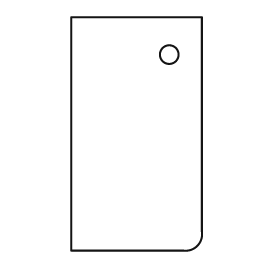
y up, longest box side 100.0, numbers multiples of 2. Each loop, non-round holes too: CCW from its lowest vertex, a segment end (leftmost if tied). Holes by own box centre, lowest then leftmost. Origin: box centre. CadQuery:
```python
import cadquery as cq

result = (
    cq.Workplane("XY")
    .moveTo(-28.0, -50.0)
    .lineTo(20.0, -50.0)
    .threePointArc((26.0, -48.0), (28.0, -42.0))
    .lineTo(28.0, 50.0)
    .lineTo(-28.0, 50.0)
    .close()
    .moveTo(14.0, 34.0)
    .circle(4.0)
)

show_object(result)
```